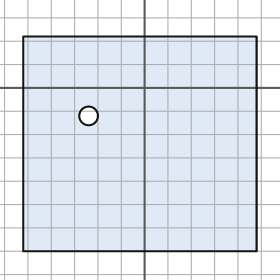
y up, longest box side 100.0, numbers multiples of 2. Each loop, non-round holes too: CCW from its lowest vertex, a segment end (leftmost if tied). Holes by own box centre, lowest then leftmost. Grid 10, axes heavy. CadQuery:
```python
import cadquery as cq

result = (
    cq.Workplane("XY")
    .moveTo(-52.0, -70.0)
    .lineTo(48.0, -70.0)
    .lineTo(48.0, 22.0)
    .lineTo(-52.0, 22.0)
    .close()
    .moveTo(-24.0, -12.0)
    .circle(4.0)
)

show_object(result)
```